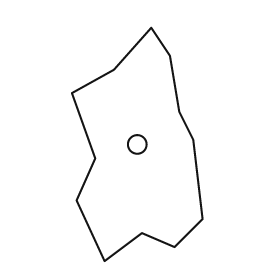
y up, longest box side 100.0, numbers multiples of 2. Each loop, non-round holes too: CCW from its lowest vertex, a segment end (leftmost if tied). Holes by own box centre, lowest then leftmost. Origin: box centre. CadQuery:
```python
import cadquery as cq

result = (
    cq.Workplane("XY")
    .moveTo(-14.0, -50.0)
    .lineTo(2.0, -38.0)
    .lineTo(16.0, -44.0)
    .lineTo(28.0, -32.0)
    .lineTo(24.0, 2.0)
    .lineTo(18.0, 14.0)
    .lineTo(14.0, 38.0)
    .lineTo(6.0, 50.0)
    .lineTo(-10.0, 32.0)
    .lineTo(-28.0, 22.0)
    .lineTo(-18.0, -6.0)
    .lineTo(-26.0, -24.0)
    .close()
    .moveTo(0.0, 0.0)
    .circle(4.0)
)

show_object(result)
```